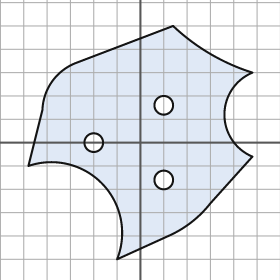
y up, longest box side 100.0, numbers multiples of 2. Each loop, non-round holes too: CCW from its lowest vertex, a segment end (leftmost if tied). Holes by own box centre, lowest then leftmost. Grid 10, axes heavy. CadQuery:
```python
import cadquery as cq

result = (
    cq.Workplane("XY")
    .moveTo(-10.0, -50.0)
    .lineTo(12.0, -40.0)
    .threePointArc((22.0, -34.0), (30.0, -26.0))
    .lineTo(48.0, -6.0)
    .threePointArc((36.0, 12.0), (48.0, 30.0))
    .threePointArc((30.0, 38.0), (14.0, 50.0))
    .lineTo(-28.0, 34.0)
    .threePointArc((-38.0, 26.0), (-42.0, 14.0))
    .lineTo(-48.0, -10.0)
    .threePointArc((-16.0, -18.0), (-10.0, -50.0))
    .close()
    .moveTo(10.0, -16.0)
    .circle(4.0)
    .moveTo(-20.0, 0.0)
    .circle(4.0)
    .moveTo(10.0, 16.0)
    .circle(4.0)
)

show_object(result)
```